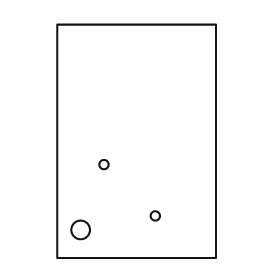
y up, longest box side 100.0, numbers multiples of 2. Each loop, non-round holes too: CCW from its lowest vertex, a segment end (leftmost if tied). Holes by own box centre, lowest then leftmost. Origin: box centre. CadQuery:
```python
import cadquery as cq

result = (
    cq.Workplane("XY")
    .moveTo(-34.0, -50.0)
    .lineTo(34.0, -50.0)
    .lineTo(34.0, 50.0)
    .lineTo(-34.0, 50.0)
    .close()
    .moveTo(-24.0, -38.0)
    .circle(4.0)
    .moveTo(8.0, -32.0)
    .circle(2.0)
    .moveTo(-14.0, -10.0)
    .circle(2.0)
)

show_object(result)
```